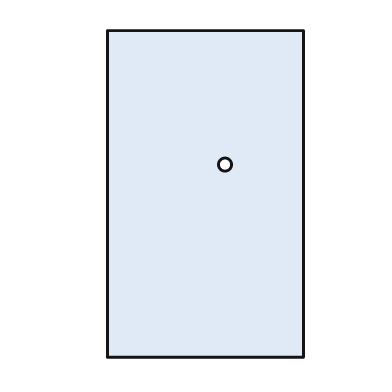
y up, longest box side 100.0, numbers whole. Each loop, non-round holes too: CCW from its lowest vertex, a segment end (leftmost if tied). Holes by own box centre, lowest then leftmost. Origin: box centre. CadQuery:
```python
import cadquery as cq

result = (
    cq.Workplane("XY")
    .moveTo(-30.0, -50.0)
    .lineTo(30.0, -50.0)
    .lineTo(30.0, 50.0)
    .lineTo(-30.0, 50.0)
    .close()
    .moveTo(6.0, 9.0)
    .circle(2.0)
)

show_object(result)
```